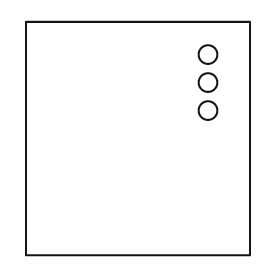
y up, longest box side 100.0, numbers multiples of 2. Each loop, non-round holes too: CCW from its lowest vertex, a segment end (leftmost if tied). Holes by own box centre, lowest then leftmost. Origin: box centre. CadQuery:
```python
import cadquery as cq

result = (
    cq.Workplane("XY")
    .moveTo(-48.0, -50.0)
    .lineTo(48.0, -50.0)
    .lineTo(48.0, 50.0)
    .lineTo(-48.0, 50.0)
    .close()
    .moveTo(30.0, 12.0)
    .circle(4.0)
    .moveTo(30.0, 24.0)
    .circle(4.0)
    .moveTo(30.0, 36.0)
    .circle(4.0)
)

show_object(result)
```